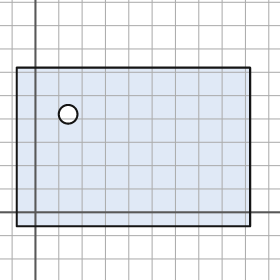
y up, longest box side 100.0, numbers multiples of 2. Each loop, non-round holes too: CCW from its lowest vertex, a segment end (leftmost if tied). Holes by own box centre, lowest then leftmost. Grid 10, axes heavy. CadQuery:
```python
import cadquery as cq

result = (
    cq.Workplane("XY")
    .moveTo(-8.0, -6.0)
    .lineTo(92.0, -6.0)
    .lineTo(92.0, 62.0)
    .lineTo(-8.0, 62.0)
    .close()
    .moveTo(14.0, 42.0)
    .circle(4.0)
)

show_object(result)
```